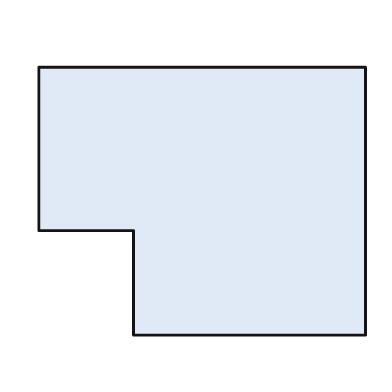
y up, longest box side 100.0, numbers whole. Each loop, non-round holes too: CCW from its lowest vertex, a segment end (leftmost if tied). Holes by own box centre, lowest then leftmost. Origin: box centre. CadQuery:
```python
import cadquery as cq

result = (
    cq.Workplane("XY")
    .moveTo(-21.0, -41.0)
    .lineTo(50.0, -41.0)
    .lineTo(50.0, 41.0)
    .lineTo(-50.0, 41.0)
    .lineTo(-50.0, -9.0)
    .lineTo(-21.0, -9.0)
    .close()
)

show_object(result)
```